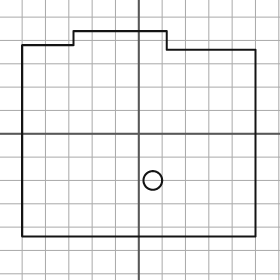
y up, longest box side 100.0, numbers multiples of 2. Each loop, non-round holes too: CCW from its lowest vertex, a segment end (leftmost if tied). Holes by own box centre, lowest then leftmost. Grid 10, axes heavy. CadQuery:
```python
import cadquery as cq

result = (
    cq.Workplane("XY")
    .moveTo(-50.0, -44.0)
    .lineTo(50.0, -44.0)
    .lineTo(50.0, 36.0)
    .lineTo(12.0, 36.0)
    .lineTo(12.0, 44.0)
    .lineTo(-28.0, 44.0)
    .lineTo(-28.0, 38.0)
    .lineTo(-50.0, 38.0)
    .close()
    .moveTo(6.0, -20.0)
    .circle(4.0)
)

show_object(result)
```